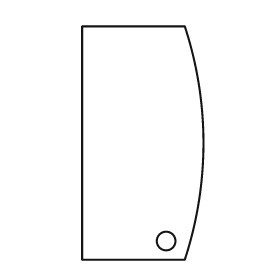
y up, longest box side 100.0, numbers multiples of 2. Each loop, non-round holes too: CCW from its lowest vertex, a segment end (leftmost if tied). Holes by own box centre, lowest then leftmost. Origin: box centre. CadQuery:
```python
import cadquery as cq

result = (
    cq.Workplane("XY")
    .moveTo(-26.0, -50.0)
    .lineTo(18.0, -50.0)
    .threePointArc((26.0, 0.0), (18.0, 50.0))
    .lineTo(-26.0, 50.0)
    .close()
    .moveTo(10.0, -42.0)
    .circle(4.0)
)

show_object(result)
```